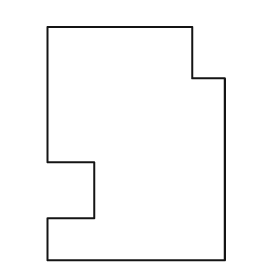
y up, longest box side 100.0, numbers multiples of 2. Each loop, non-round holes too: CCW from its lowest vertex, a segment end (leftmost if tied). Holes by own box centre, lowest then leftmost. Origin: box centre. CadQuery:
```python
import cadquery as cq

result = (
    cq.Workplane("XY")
    .moveTo(-38.0, -50.0)
    .lineTo(38.0, -50.0)
    .lineTo(38.0, 28.0)
    .lineTo(24.0, 28.0)
    .lineTo(24.0, 50.0)
    .lineTo(-38.0, 50.0)
    .lineTo(-38.0, -8.0)
    .lineTo(-18.0, -8.0)
    .lineTo(-18.0, -32.0)
    .lineTo(-38.0, -32.0)
    .close()
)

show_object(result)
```